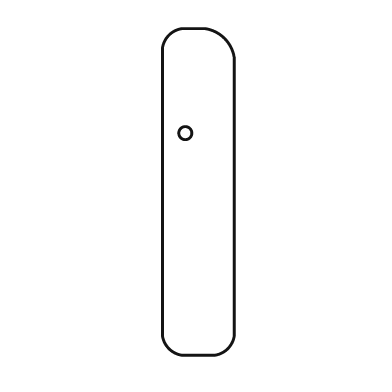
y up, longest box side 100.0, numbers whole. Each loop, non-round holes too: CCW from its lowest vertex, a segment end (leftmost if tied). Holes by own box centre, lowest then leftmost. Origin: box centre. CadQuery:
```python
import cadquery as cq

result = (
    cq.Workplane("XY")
    .moveTo(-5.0, -50.0)
    .lineTo(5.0, -50.0)
    .threePointArc((9.0, -48.0), (11.0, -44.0))
    .lineTo(11.0, 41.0)
    .threePointArc((8.0, 47.0), (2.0, 50.0))
    .lineTo(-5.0, 50.0)
    .threePointArc((-9.0, 48.0), (-11.0, 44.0))
    .lineTo(-11.0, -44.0)
    .threePointArc((-9.0, -48.0), (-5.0, -50.0))
    .close()
    .moveTo(-4.0, 18.0)
    .circle(2.0)
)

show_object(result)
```